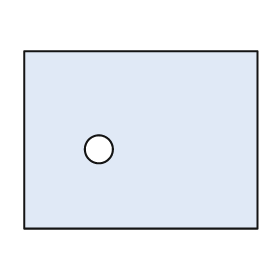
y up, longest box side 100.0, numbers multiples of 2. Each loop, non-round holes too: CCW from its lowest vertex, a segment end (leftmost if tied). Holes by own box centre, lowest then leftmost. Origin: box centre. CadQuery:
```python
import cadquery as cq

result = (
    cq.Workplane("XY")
    .moveTo(-50.0, -38.0)
    .lineTo(50.0, -38.0)
    .lineTo(50.0, 38.0)
    .lineTo(-50.0, 38.0)
    .close()
    .moveTo(-18.0, -4.0)
    .circle(6.0)
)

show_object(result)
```